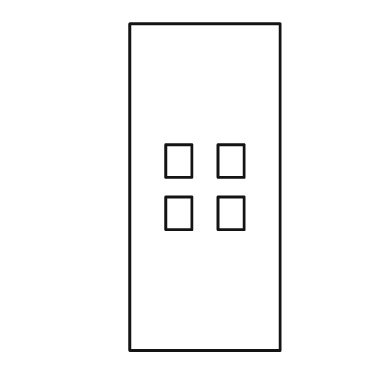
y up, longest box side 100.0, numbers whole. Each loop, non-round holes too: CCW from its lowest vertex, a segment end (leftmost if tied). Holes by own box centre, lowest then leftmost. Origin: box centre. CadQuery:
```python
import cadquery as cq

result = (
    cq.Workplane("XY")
    .moveTo(-23.0, -50.0)
    .lineTo(23.0, -50.0)
    .lineTo(23.0, 50.0)
    .lineTo(-23.0, 50.0)
    .close()
    .moveTo(-12.0, -13.0)
    .lineTo(-4.0, -13.0)
    .lineTo(-4.0, -3.0)
    .lineTo(-12.0, -3.0)
    .close()
    .moveTo(4.0, -13.0)
    .lineTo(12.0, -13.0)
    .lineTo(12.0, -3.0)
    .lineTo(4.0, -3.0)
    .close()
    .moveTo(-12.0, 3.0)
    .lineTo(-4.0, 3.0)
    .lineTo(-4.0, 13.0)
    .lineTo(-12.0, 13.0)
    .close()
    .moveTo(4.0, 3.0)
    .lineTo(12.0, 3.0)
    .lineTo(12.0, 13.0)
    .lineTo(4.0, 13.0)
    .close()
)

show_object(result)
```